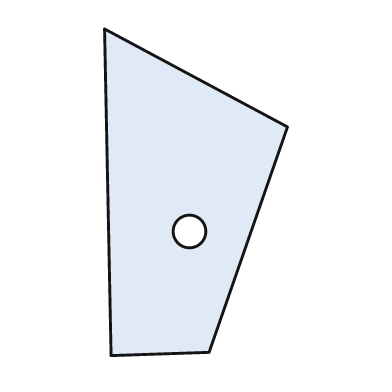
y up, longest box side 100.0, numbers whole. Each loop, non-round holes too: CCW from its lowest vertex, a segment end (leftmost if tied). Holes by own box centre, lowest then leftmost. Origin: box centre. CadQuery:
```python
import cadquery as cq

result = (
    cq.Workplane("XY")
    .moveTo(-26.0, -50.0)
    .lineTo(4.0, -49.0)
    .lineTo(28.0, 20.0)
    .lineTo(-28.0, 50.0)
    .close()
    .moveTo(-2.0, -12.0)
    .circle(5.0)
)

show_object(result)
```